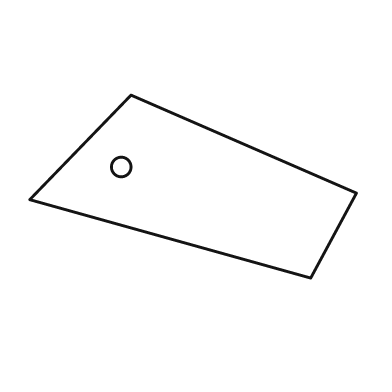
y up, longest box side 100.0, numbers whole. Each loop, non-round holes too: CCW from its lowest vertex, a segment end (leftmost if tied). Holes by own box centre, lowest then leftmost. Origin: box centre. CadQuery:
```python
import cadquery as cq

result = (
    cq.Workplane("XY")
    .moveTo(36.0, -28.0)
    .lineTo(50.0, -2.0)
    .lineTo(-19.0, 28.0)
    .lineTo(-50.0, -4.0)
    .close()
    .moveTo(-22.0, 6.0)
    .circle(3.0)
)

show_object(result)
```